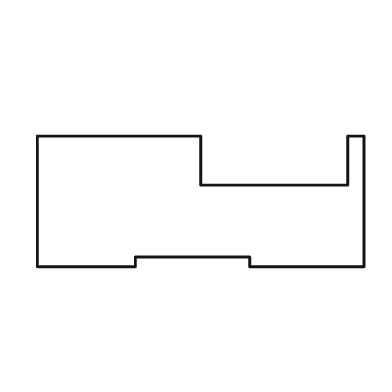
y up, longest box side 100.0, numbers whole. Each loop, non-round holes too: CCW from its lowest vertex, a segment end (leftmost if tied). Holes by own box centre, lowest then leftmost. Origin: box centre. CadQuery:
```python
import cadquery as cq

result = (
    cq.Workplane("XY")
    .moveTo(-50.0, -20.0)
    .lineTo(-20.0, -20.0)
    .lineTo(-20.0, -17.0)
    .lineTo(15.0, -17.0)
    .lineTo(15.0, -20.0)
    .lineTo(50.0, -20.0)
    .lineTo(50.0, 20.0)
    .lineTo(45.0, 20.0)
    .lineTo(45.0, 5.0)
    .lineTo(0.0, 5.0)
    .lineTo(0.0, 20.0)
    .lineTo(-50.0, 20.0)
    .close()
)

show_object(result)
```